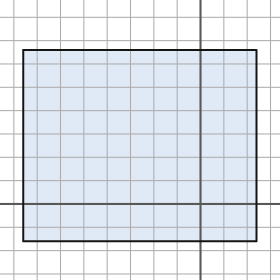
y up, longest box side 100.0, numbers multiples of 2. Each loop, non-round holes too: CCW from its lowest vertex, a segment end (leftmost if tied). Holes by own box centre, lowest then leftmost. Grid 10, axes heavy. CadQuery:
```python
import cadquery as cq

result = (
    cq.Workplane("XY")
    .moveTo(-76.0, -16.0)
    .lineTo(24.0, -16.0)
    .lineTo(24.0, 66.0)
    .lineTo(-76.0, 66.0)
    .close()
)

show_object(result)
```